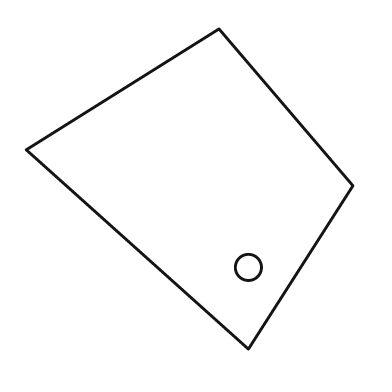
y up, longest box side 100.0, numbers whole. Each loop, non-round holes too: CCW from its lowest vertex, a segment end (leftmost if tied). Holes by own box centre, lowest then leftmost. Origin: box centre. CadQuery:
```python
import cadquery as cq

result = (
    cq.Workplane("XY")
    .moveTo(18.0, -49.0)
    .lineTo(50.0, 1.0)
    .lineTo(9.0, 49.0)
    .lineTo(-50.0, 12.0)
    .close()
    .moveTo(18.0, -24.0)
    .circle(4.0)
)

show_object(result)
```